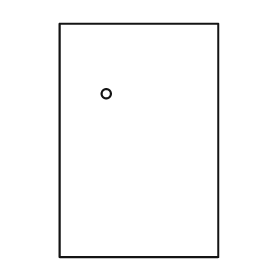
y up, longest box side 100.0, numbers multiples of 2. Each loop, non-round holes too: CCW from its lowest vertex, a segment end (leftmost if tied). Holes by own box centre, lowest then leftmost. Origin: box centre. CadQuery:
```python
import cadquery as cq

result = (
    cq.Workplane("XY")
    .moveTo(-34.0, -50.0)
    .lineTo(34.0, -50.0)
    .lineTo(34.0, 50.0)
    .lineTo(-34.0, 50.0)
    .close()
    .moveTo(-14.0, 20.0)
    .circle(2.0)
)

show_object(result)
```